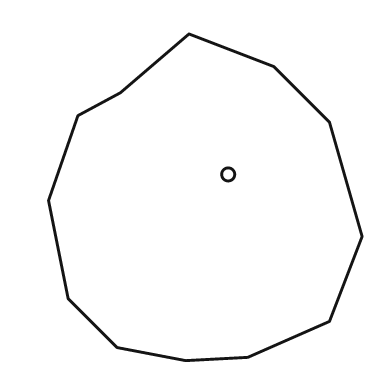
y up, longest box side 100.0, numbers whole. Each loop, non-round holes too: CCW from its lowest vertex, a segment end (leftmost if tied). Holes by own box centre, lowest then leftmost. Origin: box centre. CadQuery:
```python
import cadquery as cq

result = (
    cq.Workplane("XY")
    .moveTo(-6.0, -50.0)
    .lineTo(13.0, -49.0)
    .lineTo(38.0, -38.0)
    .lineTo(48.0, -12.0)
    .lineTo(38.0, 23.0)
    .lineTo(21.0, 40.0)
    .lineTo(-5.0, 50.0)
    .lineTo(-26.0, 32.0)
    .lineTo(-39.0, 25.0)
    .lineTo(-48.0, -1.0)
    .lineTo(-42.0, -31.0)
    .lineTo(-27.0, -46.0)
    .close()
    .moveTo(7.0, 7.0)
    .circle(2.0)
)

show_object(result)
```